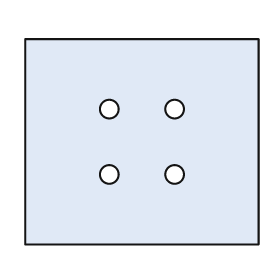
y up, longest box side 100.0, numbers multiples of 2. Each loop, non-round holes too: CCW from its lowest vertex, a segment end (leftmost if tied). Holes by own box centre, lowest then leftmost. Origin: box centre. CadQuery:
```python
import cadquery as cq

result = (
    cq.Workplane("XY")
    .moveTo(-50.0, -44.0)
    .lineTo(50.0, -44.0)
    .lineTo(50.0, 44.0)
    .lineTo(-50.0, 44.0)
    .close()
    .moveTo(-14.0, -14.0)
    .circle(4.0)
    .moveTo(14.0, -14.0)
    .circle(4.0)
    .moveTo(-14.0, 14.0)
    .circle(4.0)
    .moveTo(14.0, 14.0)
    .circle(4.0)
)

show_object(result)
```